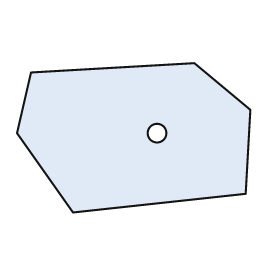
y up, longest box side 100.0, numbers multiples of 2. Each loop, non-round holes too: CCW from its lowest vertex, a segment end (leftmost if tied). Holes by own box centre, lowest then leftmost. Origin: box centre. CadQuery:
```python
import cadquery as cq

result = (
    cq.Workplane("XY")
    .moveTo(-26.0, -32.0)
    .lineTo(48.0, -24.0)
    .lineTo(50.0, 12.0)
    .lineTo(26.0, 32.0)
    .lineTo(-44.0, 28.0)
    .lineTo(-50.0, 2.0)
    .close()
    .moveTo(10.0, 2.0)
    .circle(4.0)
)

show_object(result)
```